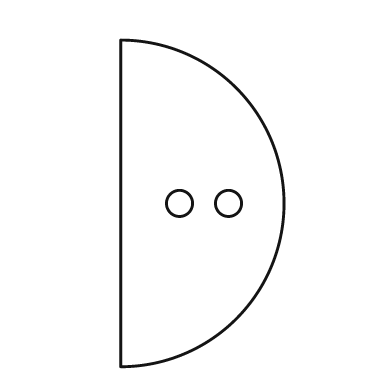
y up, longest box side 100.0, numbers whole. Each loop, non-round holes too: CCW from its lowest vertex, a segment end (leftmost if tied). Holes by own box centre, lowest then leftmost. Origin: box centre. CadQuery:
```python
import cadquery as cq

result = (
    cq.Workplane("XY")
    .moveTo(-25.0, -50.0)
    .threePointArc((25.0, 0.0), (-25.0, 50.0))
    .close()
    .moveTo(-7.0, 0.0)
    .circle(4.0)
    .moveTo(8.0, 0.0)
    .circle(4.0)
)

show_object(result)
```